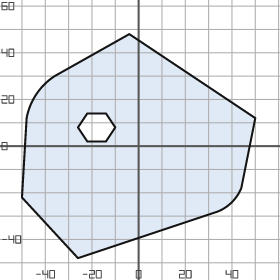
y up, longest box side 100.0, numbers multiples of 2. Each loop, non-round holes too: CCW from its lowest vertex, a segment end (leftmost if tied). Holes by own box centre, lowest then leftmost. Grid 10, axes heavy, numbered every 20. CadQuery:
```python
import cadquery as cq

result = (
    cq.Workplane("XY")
    .moveTo(-26.0, -48.0)
    .lineTo(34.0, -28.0)
    .threePointArc((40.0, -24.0), (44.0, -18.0))
    .lineTo(50.0, 12.0)
    .lineTo(-4.0, 48.0)
    .lineTo(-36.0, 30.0)
    .threePointArc((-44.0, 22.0), (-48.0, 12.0))
    .lineTo(-50.0, -22.0)
    .close()
    .moveTo(-22.0, 2.0)
    .lineTo(-14.0, 2.0)
    .lineTo(-10.0, 8.0)
    .lineTo(-14.0, 14.0)
    .lineTo(-22.0, 14.0)
    .lineTo(-26.0, 8.0)
    .close()
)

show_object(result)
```